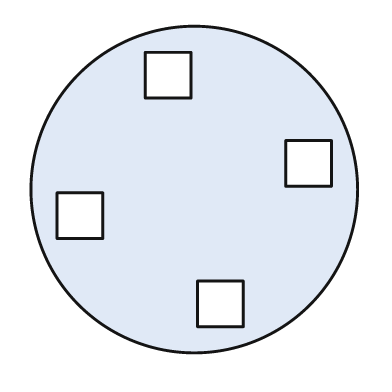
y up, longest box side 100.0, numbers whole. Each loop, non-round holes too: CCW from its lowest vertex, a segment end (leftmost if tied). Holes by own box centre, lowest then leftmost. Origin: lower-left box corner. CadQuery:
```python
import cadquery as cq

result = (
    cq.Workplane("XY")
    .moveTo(50.0, 50.0)
    .circle(50.0)
    .moveTo(51.0, 8.0)
    .lineTo(65.0, 8.0)
    .lineTo(65.0, 22.0)
    .lineTo(51.0, 22.0)
    .close()
    .moveTo(8.0, 35.0)
    .lineTo(22.0, 35.0)
    .lineTo(22.0, 49.0)
    .lineTo(8.0, 49.0)
    .close()
    .moveTo(78.0, 51.0)
    .lineTo(92.0, 51.0)
    .lineTo(92.0, 65.0)
    .lineTo(78.0, 65.0)
    .close()
    .moveTo(35.0, 78.0)
    .lineTo(49.0, 78.0)
    .lineTo(49.0, 92.0)
    .lineTo(35.0, 92.0)
    .close()
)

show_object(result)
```